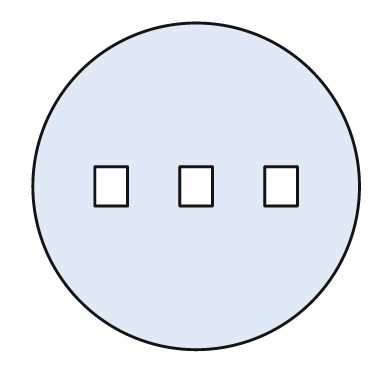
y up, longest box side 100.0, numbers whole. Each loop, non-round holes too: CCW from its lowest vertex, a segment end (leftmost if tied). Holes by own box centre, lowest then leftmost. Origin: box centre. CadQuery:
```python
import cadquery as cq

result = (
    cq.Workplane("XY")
    .moveTo(0.0, 0.0)
    .circle(50.0)
    .moveTo(-31.0, -6.0)
    .lineTo(-21.0, -6.0)
    .lineTo(-21.0, 6.0)
    .lineTo(-31.0, 6.0)
    .close()
    .moveTo(-5.0, -6.0)
    .lineTo(5.0, -6.0)
    .lineTo(5.0, 6.0)
    .lineTo(-5.0, 6.0)
    .close()
    .moveTo(21.0, -6.0)
    .lineTo(31.0, -6.0)
    .lineTo(31.0, 6.0)
    .lineTo(21.0, 6.0)
    .close()
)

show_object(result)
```